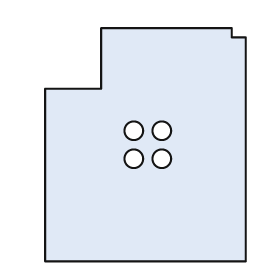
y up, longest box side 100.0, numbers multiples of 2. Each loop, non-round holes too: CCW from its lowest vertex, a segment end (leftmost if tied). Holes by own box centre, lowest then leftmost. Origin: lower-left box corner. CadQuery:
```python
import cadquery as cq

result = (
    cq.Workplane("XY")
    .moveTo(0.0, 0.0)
    .lineTo(86.0, 0.0)
    .lineTo(86.0, 96.0)
    .lineTo(80.0, 96.0)
    .lineTo(80.0, 100.0)
    .lineTo(24.0, 100.0)
    .lineTo(24.0, 74.0)
    .lineTo(0.0, 74.0)
    .close()
    .moveTo(38.0, 44.0)
    .circle(4.0)
    .moveTo(50.0, 44.0)
    .circle(4.0)
    .moveTo(38.0, 56.0)
    .circle(4.0)
    .moveTo(50.0, 56.0)
    .circle(4.0)
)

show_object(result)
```